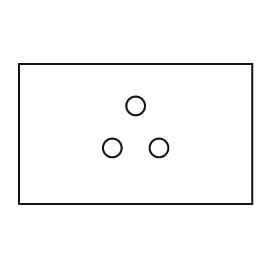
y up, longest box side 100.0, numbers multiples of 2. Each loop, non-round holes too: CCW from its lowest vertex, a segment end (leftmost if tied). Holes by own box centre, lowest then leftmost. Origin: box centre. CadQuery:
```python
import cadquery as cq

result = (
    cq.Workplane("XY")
    .moveTo(-50.0, -30.0)
    .lineTo(50.0, -30.0)
    .lineTo(50.0, 30.0)
    .lineTo(-50.0, 30.0)
    .close()
    .moveTo(-10.0, -6.0)
    .circle(4.0)
    .moveTo(10.0, -6.0)
    .circle(4.0)
    .moveTo(0.0, 12.0)
    .circle(4.0)
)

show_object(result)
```